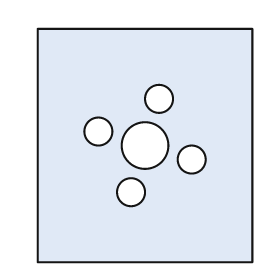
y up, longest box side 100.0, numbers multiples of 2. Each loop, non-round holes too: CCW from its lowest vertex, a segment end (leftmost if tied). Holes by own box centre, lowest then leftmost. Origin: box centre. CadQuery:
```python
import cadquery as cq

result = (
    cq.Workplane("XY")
    .moveTo(-46.0, -50.0)
    .lineTo(46.0, -50.0)
    .lineTo(46.0, 50.0)
    .lineTo(-46.0, 50.0)
    .close()
    .moveTo(-6.0, -20.0)
    .circle(6.0)
    .moveTo(20.0, -6.0)
    .circle(6.0)
    .moveTo(0.0, 0.0)
    .circle(10.0)
    .moveTo(-20.0, 6.0)
    .circle(6.0)
    .moveTo(6.0, 20.0)
    .circle(6.0)
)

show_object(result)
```